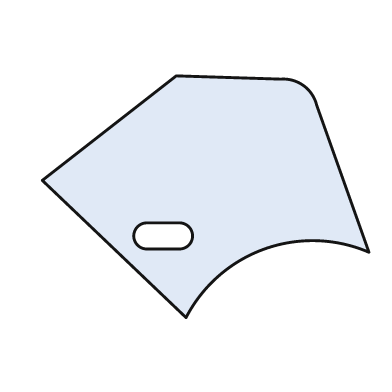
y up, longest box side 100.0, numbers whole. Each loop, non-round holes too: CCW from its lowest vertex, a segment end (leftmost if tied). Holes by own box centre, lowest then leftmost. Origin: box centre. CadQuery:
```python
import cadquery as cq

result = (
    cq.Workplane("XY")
    .moveTo(-6.0, -37.0)
    .threePointArc((18.0, -16.0), (50.0, -17.0))
    .lineTo(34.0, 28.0)
    .threePointArc((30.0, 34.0), (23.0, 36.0))
    .lineTo(-9.0, 37.0)
    .lineTo(-50.0, 5.0)
    .close()
    .moveTo(-18.0, -16.0)
    .lineTo(-8.0, -16.0)
    .threePointArc((-4.0, -12.0), (-8.0, -8.0))
    .lineTo(-18.0, -8.0)
    .threePointArc((-22.0, -12.0), (-18.0, -16.0))
    .close()
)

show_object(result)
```